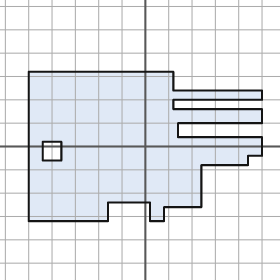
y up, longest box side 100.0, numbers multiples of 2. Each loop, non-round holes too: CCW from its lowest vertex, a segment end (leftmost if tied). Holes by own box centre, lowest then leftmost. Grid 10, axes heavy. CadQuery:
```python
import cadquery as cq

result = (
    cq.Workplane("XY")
    .moveTo(-50.0, -32.0)
    .lineTo(-16.0, -32.0)
    .lineTo(-16.0, -24.0)
    .lineTo(2.0, -24.0)
    .lineTo(2.0, -32.0)
    .lineTo(8.0, -32.0)
    .lineTo(8.0, -26.0)
    .lineTo(24.0, -26.0)
    .lineTo(24.0, -8.0)
    .lineTo(44.0, -8.0)
    .lineTo(44.0, -4.0)
    .lineTo(50.0, -4.0)
    .lineTo(50.0, 4.0)
    .lineTo(14.0, 4.0)
    .lineTo(14.0, 10.0)
    .lineTo(50.0, 10.0)
    .lineTo(50.0, 16.0)
    .lineTo(12.0, 16.0)
    .lineTo(12.0, 20.0)
    .lineTo(50.0, 20.0)
    .lineTo(50.0, 24.0)
    .lineTo(12.0, 24.0)
    .lineTo(12.0, 32.0)
    .lineTo(-50.0, 32.0)
    .close()
    .moveTo(-44.0, -6.0)
    .lineTo(-36.0, -6.0)
    .lineTo(-36.0, 2.0)
    .lineTo(-44.0, 2.0)
    .close()
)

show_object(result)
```